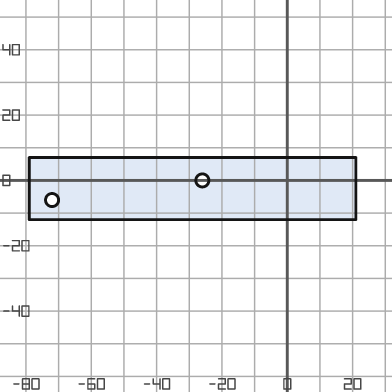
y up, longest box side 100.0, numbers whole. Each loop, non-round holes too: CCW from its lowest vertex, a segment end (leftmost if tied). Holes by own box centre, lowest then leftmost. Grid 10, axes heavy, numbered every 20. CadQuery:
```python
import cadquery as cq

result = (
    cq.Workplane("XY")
    .moveTo(-79.0, -12.0)
    .lineTo(21.0, -12.0)
    .lineTo(21.0, 7.0)
    .lineTo(-79.0, 7.0)
    .close()
    .moveTo(-72.0, -6.0)
    .circle(2.0)
    .moveTo(-26.0, 0.0)
    .circle(2.0)
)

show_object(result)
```